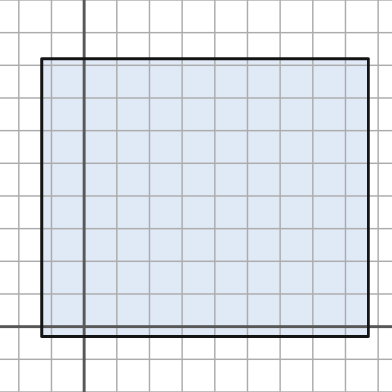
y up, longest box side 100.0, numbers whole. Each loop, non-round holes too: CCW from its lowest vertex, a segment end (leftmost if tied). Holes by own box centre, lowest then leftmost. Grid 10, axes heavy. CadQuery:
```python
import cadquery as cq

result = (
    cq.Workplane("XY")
    .moveTo(-13.0, -3.0)
    .lineTo(87.0, -3.0)
    .lineTo(87.0, 82.0)
    .lineTo(-13.0, 82.0)
    .close()
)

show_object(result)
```